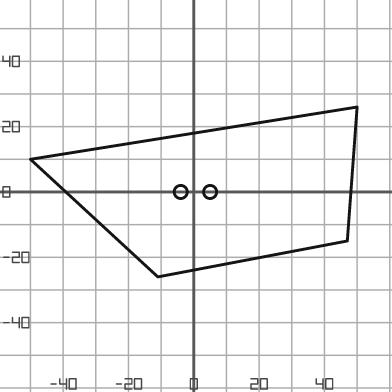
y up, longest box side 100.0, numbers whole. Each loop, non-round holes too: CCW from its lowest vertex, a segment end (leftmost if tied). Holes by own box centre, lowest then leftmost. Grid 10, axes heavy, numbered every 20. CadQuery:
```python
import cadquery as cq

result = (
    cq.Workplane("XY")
    .moveTo(-11.0, -26.0)
    .lineTo(47.0, -15.0)
    .lineTo(50.0, 26.0)
    .lineTo(-50.0, 10.0)
    .close()
    .moveTo(-4.0, 0.0)
    .circle(2.0)
    .moveTo(5.0, 0.0)
    .circle(2.0)
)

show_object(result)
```